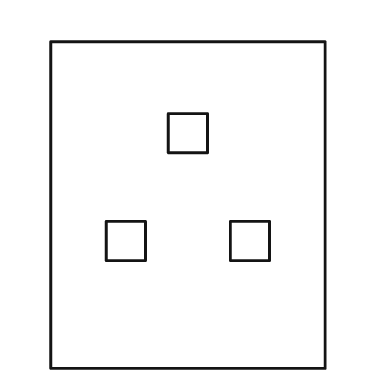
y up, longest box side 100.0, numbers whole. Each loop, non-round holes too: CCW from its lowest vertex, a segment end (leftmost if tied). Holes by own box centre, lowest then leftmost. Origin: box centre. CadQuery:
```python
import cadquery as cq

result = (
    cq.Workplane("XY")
    .moveTo(-42.0, -50.0)
    .lineTo(42.0, -50.0)
    .lineTo(42.0, 50.0)
    .lineTo(-42.0, 50.0)
    .close()
    .moveTo(-25.0, -17.0)
    .lineTo(-13.0, -17.0)
    .lineTo(-13.0, -5.0)
    .lineTo(-25.0, -5.0)
    .close()
    .moveTo(13.0, -17.0)
    .lineTo(25.0, -17.0)
    .lineTo(25.0, -5.0)
    .lineTo(13.0, -5.0)
    .close()
    .moveTo(-6.0, 16.0)
    .lineTo(6.0, 16.0)
    .lineTo(6.0, 28.0)
    .lineTo(-6.0, 28.0)
    .close()
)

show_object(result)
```